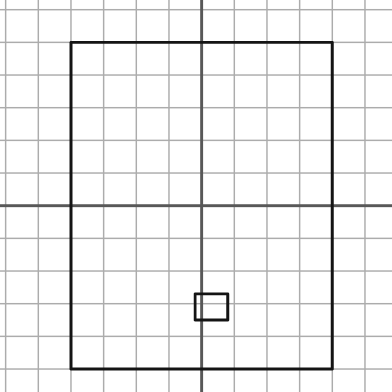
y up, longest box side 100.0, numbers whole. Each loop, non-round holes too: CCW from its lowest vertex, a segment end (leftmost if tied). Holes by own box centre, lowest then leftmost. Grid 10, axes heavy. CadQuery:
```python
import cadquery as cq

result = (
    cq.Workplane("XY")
    .moveTo(-40.0, -50.0)
    .lineTo(40.0, -50.0)
    .lineTo(40.0, 50.0)
    .lineTo(-40.0, 50.0)
    .close()
    .moveTo(-2.0, -35.0)
    .lineTo(8.0, -35.0)
    .lineTo(8.0, -27.0)
    .lineTo(-2.0, -27.0)
    .close()
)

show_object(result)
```